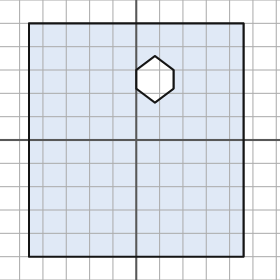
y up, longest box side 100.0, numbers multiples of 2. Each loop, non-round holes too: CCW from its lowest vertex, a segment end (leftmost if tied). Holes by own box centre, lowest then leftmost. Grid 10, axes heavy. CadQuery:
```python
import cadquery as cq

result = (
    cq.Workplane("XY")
    .moveTo(-46.0, -50.0)
    .lineTo(46.0, -50.0)
    .lineTo(46.0, 50.0)
    .lineTo(-46.0, 50.0)
    .close()
    .moveTo(8.0, 16.0)
    .lineTo(16.0, 22.0)
    .lineTo(16.0, 30.0)
    .lineTo(8.0, 36.0)
    .lineTo(0.0, 30.0)
    .lineTo(0.0, 22.0)
    .close()
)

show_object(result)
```